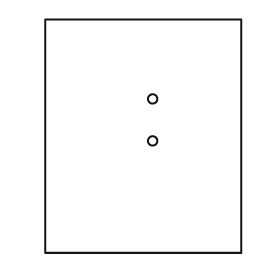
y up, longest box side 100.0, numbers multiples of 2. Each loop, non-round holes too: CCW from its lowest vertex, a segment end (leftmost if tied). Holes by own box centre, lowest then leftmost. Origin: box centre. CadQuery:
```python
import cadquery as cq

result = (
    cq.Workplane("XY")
    .moveTo(-42.0, -50.0)
    .lineTo(42.0, -50.0)
    .lineTo(42.0, 50.0)
    .lineTo(-42.0, 50.0)
    .close()
    .moveTo(4.0, -2.0)
    .circle(2.0)
    .moveTo(4.0, 16.0)
    .circle(2.0)
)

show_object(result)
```